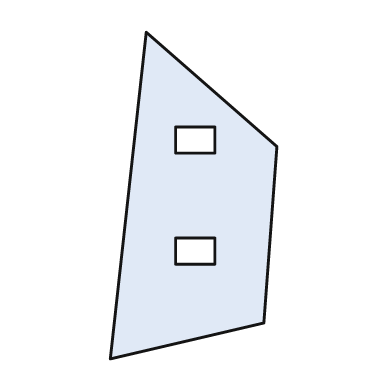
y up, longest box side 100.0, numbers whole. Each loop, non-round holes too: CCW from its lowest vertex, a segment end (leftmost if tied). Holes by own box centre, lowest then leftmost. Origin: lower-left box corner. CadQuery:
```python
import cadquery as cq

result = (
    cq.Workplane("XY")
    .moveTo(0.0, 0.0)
    .lineTo(47.0, 11.0)
    .lineTo(51.0, 65.0)
    .lineTo(11.0, 100.0)
    .close()
    .moveTo(20.0, 29.0)
    .lineTo(32.0, 29.0)
    .lineTo(32.0, 37.0)
    .lineTo(20.0, 37.0)
    .close()
    .moveTo(20.0, 63.0)
    .lineTo(32.0, 63.0)
    .lineTo(32.0, 71.0)
    .lineTo(20.0, 71.0)
    .close()
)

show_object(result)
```